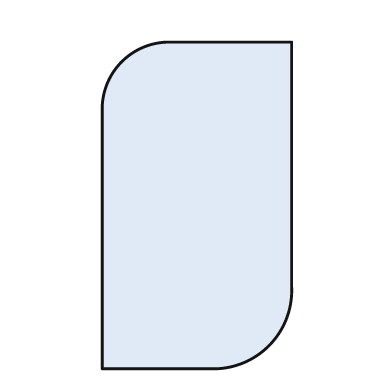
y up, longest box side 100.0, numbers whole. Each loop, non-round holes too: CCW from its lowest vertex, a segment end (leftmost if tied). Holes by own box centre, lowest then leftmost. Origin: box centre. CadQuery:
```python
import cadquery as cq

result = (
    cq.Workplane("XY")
    .moveTo(-29.0, -50.0)
    .lineTo(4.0, -50.0)
    .threePointArc((22.0, -43.0), (29.0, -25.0))
    .lineTo(29.0, 50.0)
    .lineTo(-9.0, 50.0)
    .threePointArc((-23.0, 44.0), (-29.0, 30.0))
    .close()
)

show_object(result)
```